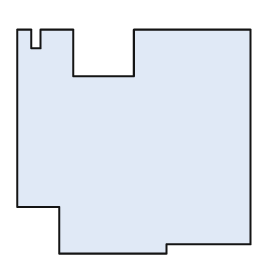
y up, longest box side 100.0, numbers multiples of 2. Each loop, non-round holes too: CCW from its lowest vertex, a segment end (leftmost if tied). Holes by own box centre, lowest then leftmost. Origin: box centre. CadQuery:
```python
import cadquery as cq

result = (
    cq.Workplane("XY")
    .moveTo(-32.0, -48.0)
    .lineTo(14.0, -48.0)
    .lineTo(14.0, -44.0)
    .lineTo(50.0, -44.0)
    .lineTo(50.0, 48.0)
    .lineTo(0.0, 48.0)
    .lineTo(0.0, 28.0)
    .lineTo(-26.0, 28.0)
    .lineTo(-26.0, 48.0)
    .lineTo(-40.0, 48.0)
    .lineTo(-40.0, 40.0)
    .lineTo(-44.0, 40.0)
    .lineTo(-44.0, 48.0)
    .lineTo(-50.0, 48.0)
    .lineTo(-50.0, -28.0)
    .lineTo(-32.0, -28.0)
    .close()
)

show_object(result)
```